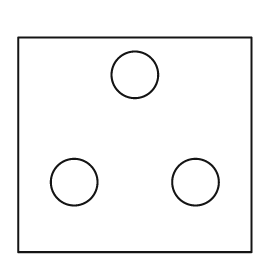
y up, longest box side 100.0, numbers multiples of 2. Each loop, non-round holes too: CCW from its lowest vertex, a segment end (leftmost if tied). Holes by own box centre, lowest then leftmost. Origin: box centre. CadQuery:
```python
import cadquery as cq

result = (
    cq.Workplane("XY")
    .moveTo(-50.0, -46.0)
    .lineTo(50.0, -46.0)
    .lineTo(50.0, 46.0)
    .lineTo(-50.0, 46.0)
    .close()
    .moveTo(-26.0, -16.0)
    .circle(10.0)
    .moveTo(26.0, -16.0)
    .circle(10.0)
    .moveTo(0.0, 30.0)
    .circle(10.0)
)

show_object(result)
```